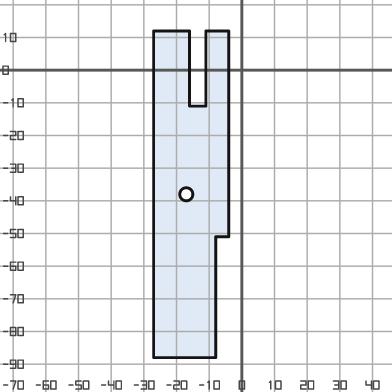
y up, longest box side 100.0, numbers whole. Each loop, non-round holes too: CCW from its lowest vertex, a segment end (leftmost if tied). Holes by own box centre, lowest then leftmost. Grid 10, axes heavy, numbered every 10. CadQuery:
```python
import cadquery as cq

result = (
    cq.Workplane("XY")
    .moveTo(-27.0, -88.0)
    .lineTo(-8.0, -88.0)
    .lineTo(-8.0, -51.0)
    .lineTo(-4.0, -51.0)
    .lineTo(-4.0, 12.0)
    .lineTo(-11.0, 12.0)
    .lineTo(-11.0, -11.0)
    .lineTo(-16.0, -11.0)
    .lineTo(-16.0, 12.0)
    .lineTo(-27.0, 12.0)
    .close()
    .moveTo(-17.0, -38.0)
    .circle(2.0)
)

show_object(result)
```